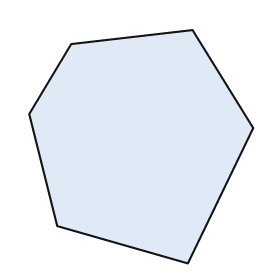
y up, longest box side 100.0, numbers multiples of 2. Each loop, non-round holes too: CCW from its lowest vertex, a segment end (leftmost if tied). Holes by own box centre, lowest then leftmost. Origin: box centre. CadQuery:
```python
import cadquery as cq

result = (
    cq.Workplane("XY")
    .moveTo(20.0, -50.0)
    .lineTo(48.0, 8.0)
    .lineTo(22.0, 50.0)
    .lineTo(-30.0, 44.0)
    .lineTo(-48.0, 14.0)
    .lineTo(-36.0, -34.0)
    .close()
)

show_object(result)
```